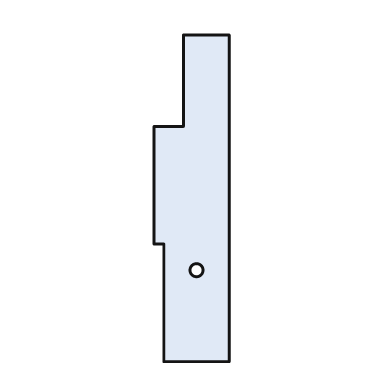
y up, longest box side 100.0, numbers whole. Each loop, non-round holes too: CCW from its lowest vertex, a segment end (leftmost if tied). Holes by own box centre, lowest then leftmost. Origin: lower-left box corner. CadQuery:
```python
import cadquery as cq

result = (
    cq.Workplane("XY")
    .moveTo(3.0, 0.0)
    .lineTo(23.0, 0.0)
    .lineTo(23.0, 100.0)
    .lineTo(9.0, 100.0)
    .lineTo(9.0, 72.0)
    .lineTo(0.0, 72.0)
    .lineTo(0.0, 36.0)
    .lineTo(3.0, 36.0)
    .close()
    .moveTo(13.0, 28.0)
    .circle(2.0)
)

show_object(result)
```